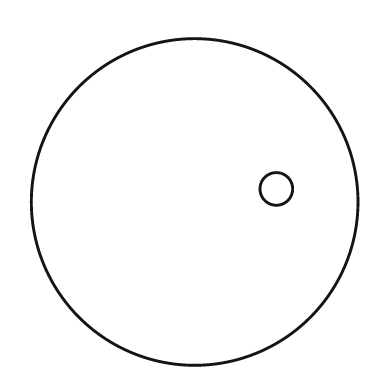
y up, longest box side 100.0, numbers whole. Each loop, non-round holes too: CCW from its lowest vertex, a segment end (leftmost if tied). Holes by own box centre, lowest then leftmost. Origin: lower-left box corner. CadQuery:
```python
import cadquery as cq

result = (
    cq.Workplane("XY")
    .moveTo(50.0, 50.0)
    .circle(50.0)
    .moveTo(75.0, 54.0)
    .circle(5.0)
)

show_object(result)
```